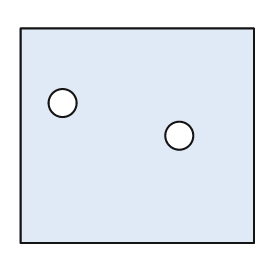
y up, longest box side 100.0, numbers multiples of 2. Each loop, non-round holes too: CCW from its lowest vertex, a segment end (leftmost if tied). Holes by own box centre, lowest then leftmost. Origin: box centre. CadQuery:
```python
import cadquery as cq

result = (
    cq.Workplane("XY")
    .moveTo(-50.0, -46.0)
    .lineTo(50.0, -46.0)
    .lineTo(50.0, 46.0)
    .lineTo(-50.0, 46.0)
    .close()
    .moveTo(18.0, 0.0)
    .circle(6.0)
    .moveTo(-32.0, 14.0)
    .circle(6.0)
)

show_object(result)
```